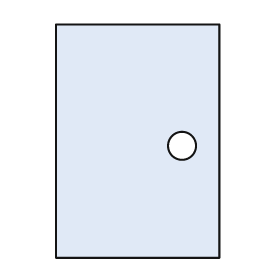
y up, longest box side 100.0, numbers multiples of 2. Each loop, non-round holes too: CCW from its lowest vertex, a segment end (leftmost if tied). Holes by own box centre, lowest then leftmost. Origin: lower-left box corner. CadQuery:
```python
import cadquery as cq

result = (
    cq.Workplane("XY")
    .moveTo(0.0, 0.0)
    .lineTo(70.0, 0.0)
    .lineTo(70.0, 100.0)
    .lineTo(0.0, 100.0)
    .close()
    .moveTo(54.0, 48.0)
    .circle(6.0)
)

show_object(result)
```